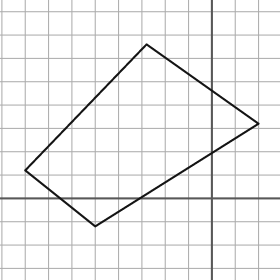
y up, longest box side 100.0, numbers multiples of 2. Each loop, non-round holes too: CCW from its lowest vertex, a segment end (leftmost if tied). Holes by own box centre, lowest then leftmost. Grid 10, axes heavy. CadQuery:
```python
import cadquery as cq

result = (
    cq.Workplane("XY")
    .moveTo(-50.0, -12.0)
    .lineTo(20.0, 32.0)
    .lineTo(-28.0, 66.0)
    .lineTo(-80.0, 12.0)
    .close()
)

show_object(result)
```